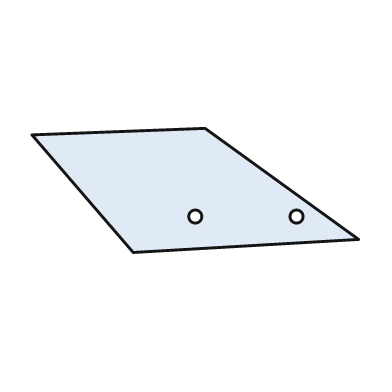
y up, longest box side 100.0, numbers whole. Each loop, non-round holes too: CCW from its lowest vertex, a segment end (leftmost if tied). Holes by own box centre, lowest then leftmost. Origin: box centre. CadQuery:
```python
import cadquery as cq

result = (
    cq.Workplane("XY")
    .moveTo(-19.0, -19.0)
    .lineTo(50.0, -15.0)
    .lineTo(3.0, 19.0)
    .lineTo(-50.0, 17.0)
    .close()
    .moveTo(0.0, -8.0)
    .circle(2.0)
    .moveTo(31.0, -8.0)
    .circle(2.0)
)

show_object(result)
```